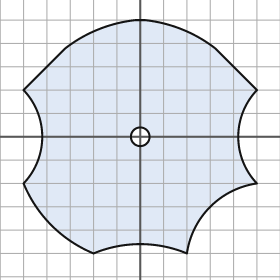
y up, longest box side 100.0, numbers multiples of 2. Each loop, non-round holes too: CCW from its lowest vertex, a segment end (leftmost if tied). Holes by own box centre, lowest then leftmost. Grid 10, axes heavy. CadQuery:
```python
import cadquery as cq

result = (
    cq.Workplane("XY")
    .moveTo(-20.0, -50.0)
    .threePointArc((0.0, -46.0), (20.0, -50.0))
    .threePointArc((30.0, -30.0), (50.0, -20.0))
    .threePointArc((42.0, 0.0), (50.0, 20.0))
    .lineTo(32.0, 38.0)
    .threePointArc((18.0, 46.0), (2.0, 50.0))
    .lineTo(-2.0, 50.0)
    .threePointArc((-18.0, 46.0), (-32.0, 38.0))
    .lineTo(-50.0, 20.0)
    .threePointArc((-42.0, 0.0), (-50.0, -20.0))
    .threePointArc((-38.0, -38.0), (-20.0, -50.0))
    .close()
    .moveTo(0.0, 0.0)
    .circle(4.0)
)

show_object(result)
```